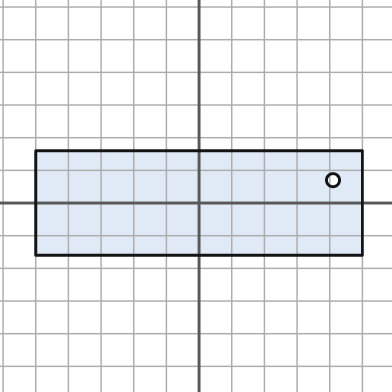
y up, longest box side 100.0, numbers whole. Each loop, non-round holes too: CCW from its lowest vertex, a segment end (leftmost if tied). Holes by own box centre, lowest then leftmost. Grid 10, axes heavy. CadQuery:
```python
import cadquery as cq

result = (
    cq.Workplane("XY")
    .moveTo(-50.0, -16.0)
    .lineTo(50.0, -16.0)
    .lineTo(50.0, 16.0)
    .lineTo(-50.0, 16.0)
    .close()
    .moveTo(41.0, 7.0)
    .circle(2.0)
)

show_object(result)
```